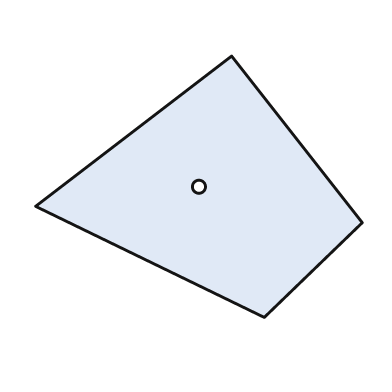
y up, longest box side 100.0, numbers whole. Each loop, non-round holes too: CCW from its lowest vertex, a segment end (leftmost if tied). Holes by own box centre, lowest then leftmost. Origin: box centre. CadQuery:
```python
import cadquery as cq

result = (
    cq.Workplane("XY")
    .moveTo(20.0, -40.0)
    .lineTo(50.0, -11.0)
    .lineTo(10.0, 40.0)
    .lineTo(-50.0, -6.0)
    .close()
    .moveTo(0.0, 0.0)
    .circle(2.0)
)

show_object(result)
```